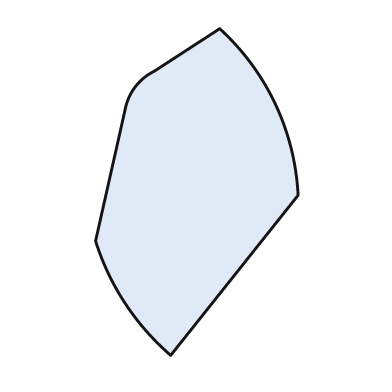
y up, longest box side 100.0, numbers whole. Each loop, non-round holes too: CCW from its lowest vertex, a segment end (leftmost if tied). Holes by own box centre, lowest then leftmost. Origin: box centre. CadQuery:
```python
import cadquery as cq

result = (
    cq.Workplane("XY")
    .moveTo(-8.0, -50.0)
    .lineTo(31.0, -1.0)
    .threePointArc((24.0, 27.0), (7.0, 50.0))
    .lineTo(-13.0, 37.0)
    .threePointArc((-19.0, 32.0), (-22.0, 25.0))
    .lineTo(-31.0, -15.0)
    .threePointArc((-22.0, -34.0), (-8.0, -50.0))
    .close()
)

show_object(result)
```